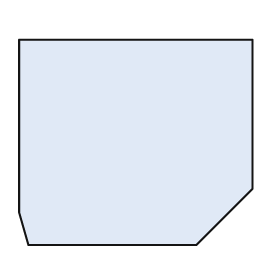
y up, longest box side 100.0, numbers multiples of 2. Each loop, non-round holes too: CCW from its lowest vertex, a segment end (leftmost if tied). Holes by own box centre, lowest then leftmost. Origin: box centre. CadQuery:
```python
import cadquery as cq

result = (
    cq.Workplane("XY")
    .moveTo(-46.0, -44.0)
    .lineTo(26.0, -44.0)
    .lineTo(50.0, -20.0)
    .lineTo(50.0, 44.0)
    .lineTo(-50.0, 44.0)
    .lineTo(-50.0, -30.0)
    .close()
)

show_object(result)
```